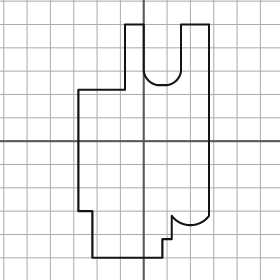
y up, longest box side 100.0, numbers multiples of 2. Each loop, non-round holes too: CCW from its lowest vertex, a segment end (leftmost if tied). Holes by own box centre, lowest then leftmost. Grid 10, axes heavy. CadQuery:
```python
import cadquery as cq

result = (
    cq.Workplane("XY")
    .moveTo(-22.0, -50.0)
    .lineTo(8.0, -50.0)
    .lineTo(8.0, -42.0)
    .lineTo(12.0, -42.0)
    .lineTo(12.0, -32.0)
    .threePointArc((20.0, -36.0), (28.0, -32.0))
    .lineTo(28.0, 50.0)
    .lineTo(16.0, 50.0)
    .lineTo(16.0, 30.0)
    .threePointArc((14.0, 26.0), (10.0, 24.0))
    .lineTo(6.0, 24.0)
    .threePointArc((2.0, 26.0), (0.0, 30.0))
    .lineTo(0.0, 50.0)
    .lineTo(-8.0, 50.0)
    .lineTo(-8.0, 22.0)
    .lineTo(-28.0, 22.0)
    .lineTo(-28.0, -30.0)
    .lineTo(-22.0, -30.0)
    .close()
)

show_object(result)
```